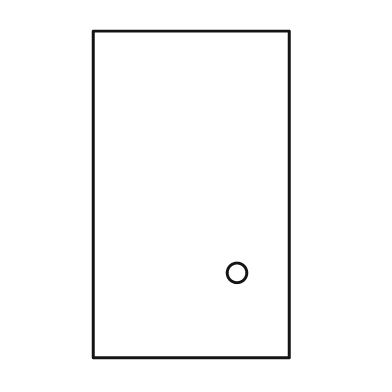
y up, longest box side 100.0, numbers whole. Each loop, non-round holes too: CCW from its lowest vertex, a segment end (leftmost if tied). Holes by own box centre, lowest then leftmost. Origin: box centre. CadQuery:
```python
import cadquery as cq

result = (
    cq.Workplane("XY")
    .moveTo(-30.0, -50.0)
    .lineTo(30.0, -50.0)
    .lineTo(30.0, 50.0)
    .lineTo(-30.0, 50.0)
    .close()
    .moveTo(14.0, -24.0)
    .circle(3.0)
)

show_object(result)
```